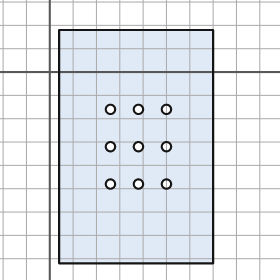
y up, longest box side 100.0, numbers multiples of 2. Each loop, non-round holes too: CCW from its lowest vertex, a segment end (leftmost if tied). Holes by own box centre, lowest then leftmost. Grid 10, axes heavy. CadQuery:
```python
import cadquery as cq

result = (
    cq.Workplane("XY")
    .moveTo(4.0, -82.0)
    .lineTo(70.0, -82.0)
    .lineTo(70.0, 18.0)
    .lineTo(4.0, 18.0)
    .close()
    .moveTo(26.0, -48.0)
    .circle(2.0)
    .moveTo(38.0, -48.0)
    .circle(2.0)
    .moveTo(50.0, -48.0)
    .circle(2.0)
    .moveTo(26.0, -32.0)
    .circle(2.0)
    .moveTo(38.0, -32.0)
    .circle(2.0)
    .moveTo(50.0, -32.0)
    .circle(2.0)
    .moveTo(26.0, -16.0)
    .circle(2.0)
    .moveTo(38.0, -16.0)
    .circle(2.0)
    .moveTo(50.0, -16.0)
    .circle(2.0)
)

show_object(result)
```